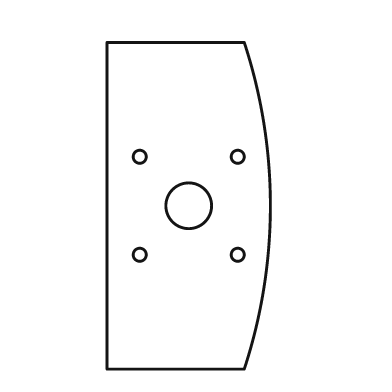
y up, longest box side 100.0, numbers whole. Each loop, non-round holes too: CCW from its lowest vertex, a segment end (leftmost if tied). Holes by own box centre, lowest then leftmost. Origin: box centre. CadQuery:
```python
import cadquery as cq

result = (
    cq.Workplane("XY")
    .moveTo(-25.0, -50.0)
    .lineTo(17.0, -50.0)
    .threePointArc((25.0, 0.0), (17.0, 50.0))
    .lineTo(-25.0, 50.0)
    .close()
    .moveTo(-15.0, -15.0)
    .circle(2.0)
    .moveTo(15.0, -15.0)
    .circle(2.0)
    .moveTo(0.0, 0.0)
    .circle(7.0)
    .moveTo(-15.0, 15.0)
    .circle(2.0)
    .moveTo(15.0, 15.0)
    .circle(2.0)
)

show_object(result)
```